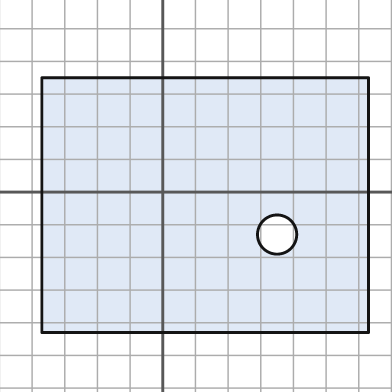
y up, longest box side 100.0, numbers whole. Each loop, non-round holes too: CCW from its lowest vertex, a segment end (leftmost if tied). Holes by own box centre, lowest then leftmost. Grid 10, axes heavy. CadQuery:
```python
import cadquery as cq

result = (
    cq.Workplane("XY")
    .moveTo(-37.0, -43.0)
    .lineTo(63.0, -43.0)
    .lineTo(63.0, 35.0)
    .lineTo(-37.0, 35.0)
    .close()
    .moveTo(35.0, -13.0)
    .circle(6.0)
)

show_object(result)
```